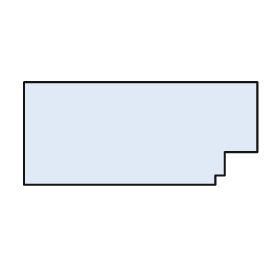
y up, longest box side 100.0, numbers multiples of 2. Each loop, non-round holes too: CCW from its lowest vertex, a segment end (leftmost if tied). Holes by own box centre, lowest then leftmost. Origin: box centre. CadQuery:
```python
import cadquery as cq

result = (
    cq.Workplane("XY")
    .moveTo(-50.0, -22.0)
    .lineTo(32.0, -22.0)
    .lineTo(32.0, -18.0)
    .lineTo(36.0, -18.0)
    .lineTo(36.0, -8.0)
    .lineTo(50.0, -8.0)
    .lineTo(50.0, 22.0)
    .lineTo(-50.0, 22.0)
    .close()
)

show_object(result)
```